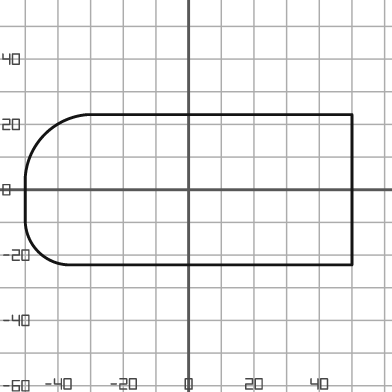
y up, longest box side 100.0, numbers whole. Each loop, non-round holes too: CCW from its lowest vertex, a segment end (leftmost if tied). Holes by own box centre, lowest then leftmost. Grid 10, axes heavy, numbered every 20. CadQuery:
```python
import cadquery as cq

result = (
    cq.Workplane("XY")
    .moveTo(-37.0, -23.0)
    .lineTo(50.0, -23.0)
    .lineTo(50.0, 23.0)
    .lineTo(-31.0, 23.0)
    .threePointArc((-44.0, 17.0), (-50.0, 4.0))
    .lineTo(-50.0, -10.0)
    .threePointArc((-46.0, -19.0), (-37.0, -23.0))
    .close()
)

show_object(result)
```